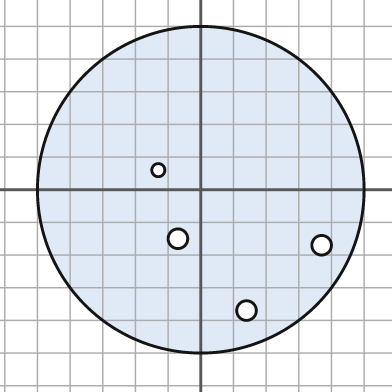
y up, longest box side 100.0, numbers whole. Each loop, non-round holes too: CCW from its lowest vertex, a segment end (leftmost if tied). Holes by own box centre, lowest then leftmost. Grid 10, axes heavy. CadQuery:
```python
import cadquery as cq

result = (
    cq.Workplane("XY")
    .moveTo(0.0, 0.0)
    .circle(50.0)
    .moveTo(14.0, -37.0)
    .circle(3.0)
    .moveTo(37.0, -17.0)
    .circle(3.0)
    .moveTo(-7.0, -15.0)
    .circle(3.0)
    .moveTo(-13.0, 6.0)
    .circle(2.0)
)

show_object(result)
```